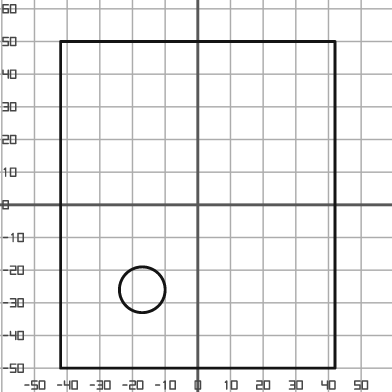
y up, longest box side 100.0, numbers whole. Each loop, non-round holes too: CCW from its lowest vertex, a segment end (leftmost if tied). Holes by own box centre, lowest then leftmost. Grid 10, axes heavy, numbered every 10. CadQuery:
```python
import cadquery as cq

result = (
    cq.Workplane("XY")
    .moveTo(-42.0, -50.0)
    .lineTo(42.0, -50.0)
    .lineTo(42.0, 50.0)
    .lineTo(-42.0, 50.0)
    .close()
    .moveTo(-17.0, -26.0)
    .circle(7.0)
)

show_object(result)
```